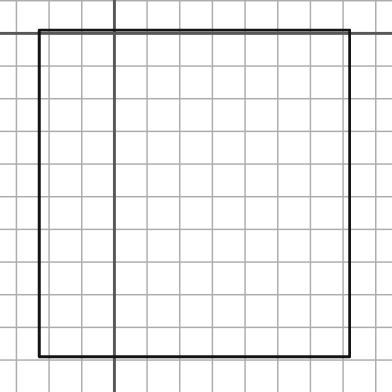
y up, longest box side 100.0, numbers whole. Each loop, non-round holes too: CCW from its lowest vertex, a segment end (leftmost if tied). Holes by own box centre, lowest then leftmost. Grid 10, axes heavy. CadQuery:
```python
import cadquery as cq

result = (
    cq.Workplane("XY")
    .moveTo(-23.0, -99.0)
    .lineTo(72.0, -99.0)
    .lineTo(72.0, 1.0)
    .lineTo(-23.0, 1.0)
    .close()
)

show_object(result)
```